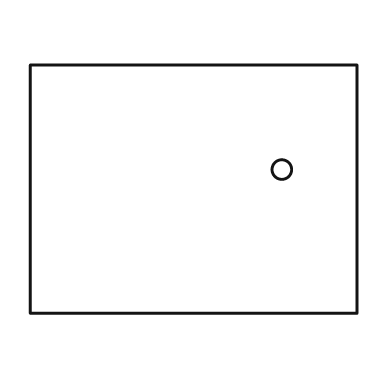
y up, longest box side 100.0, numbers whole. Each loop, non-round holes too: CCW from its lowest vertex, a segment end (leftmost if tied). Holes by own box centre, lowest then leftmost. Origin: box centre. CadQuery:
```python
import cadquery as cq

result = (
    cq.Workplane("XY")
    .moveTo(-50.0, -38.0)
    .lineTo(50.0, -38.0)
    .lineTo(50.0, 38.0)
    .lineTo(-50.0, 38.0)
    .close()
    .moveTo(27.0, 6.0)
    .circle(3.0)
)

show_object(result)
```